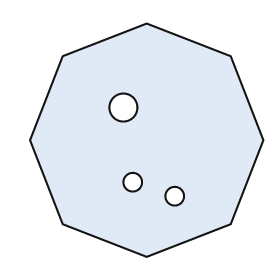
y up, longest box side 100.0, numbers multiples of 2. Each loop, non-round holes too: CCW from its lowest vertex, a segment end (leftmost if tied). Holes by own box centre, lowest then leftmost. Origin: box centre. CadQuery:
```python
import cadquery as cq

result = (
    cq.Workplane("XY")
    .moveTo(0.0, -50.0)
    .lineTo(36.0, -36.0)
    .lineTo(50.0, 0.0)
    .lineTo(36.0, 36.0)
    .lineTo(0.0, 50.0)
    .lineTo(-36.0, 36.0)
    .lineTo(-50.0, 0.0)
    .lineTo(-36.0, -36.0)
    .close()
    .moveTo(12.0, -24.0)
    .circle(4.0)
    .moveTo(-6.0, -18.0)
    .circle(4.0)
    .moveTo(-10.0, 14.0)
    .circle(6.0)
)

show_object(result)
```